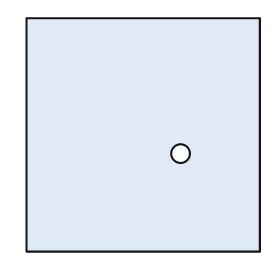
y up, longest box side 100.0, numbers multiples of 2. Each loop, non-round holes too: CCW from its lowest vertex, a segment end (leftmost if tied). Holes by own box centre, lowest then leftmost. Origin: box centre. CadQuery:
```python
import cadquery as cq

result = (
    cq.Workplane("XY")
    .moveTo(-50.0, -50.0)
    .lineTo(50.0, -50.0)
    .lineTo(50.0, 50.0)
    .lineTo(-50.0, 50.0)
    .close()
    .moveTo(16.0, -8.0)
    .circle(4.0)
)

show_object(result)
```